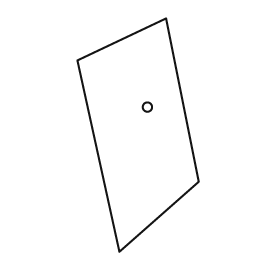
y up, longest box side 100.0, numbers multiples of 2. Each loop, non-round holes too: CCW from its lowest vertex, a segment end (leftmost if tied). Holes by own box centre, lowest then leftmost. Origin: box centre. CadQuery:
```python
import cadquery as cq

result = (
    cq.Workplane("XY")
    .moveTo(-8.0, -50.0)
    .lineTo(26.0, -20.0)
    .lineTo(12.0, 50.0)
    .lineTo(-26.0, 32.0)
    .close()
    .moveTo(4.0, 12.0)
    .circle(2.0)
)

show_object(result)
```